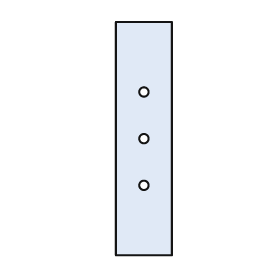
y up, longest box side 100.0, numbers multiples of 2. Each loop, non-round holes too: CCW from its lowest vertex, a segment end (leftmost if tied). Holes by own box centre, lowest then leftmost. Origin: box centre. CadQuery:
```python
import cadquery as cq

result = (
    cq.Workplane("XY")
    .moveTo(-12.0, -50.0)
    .lineTo(12.0, -50.0)
    .lineTo(12.0, 50.0)
    .lineTo(-12.0, 50.0)
    .close()
    .moveTo(0.0, -20.0)
    .circle(2.0)
    .moveTo(0.0, 0.0)
    .circle(2.0)
    .moveTo(0.0, 20.0)
    .circle(2.0)
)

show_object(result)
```